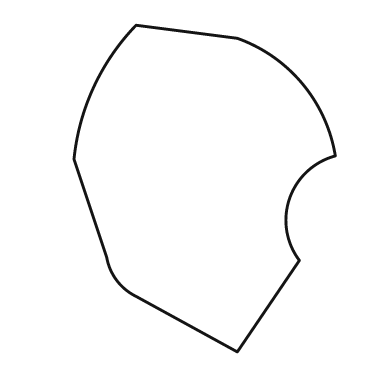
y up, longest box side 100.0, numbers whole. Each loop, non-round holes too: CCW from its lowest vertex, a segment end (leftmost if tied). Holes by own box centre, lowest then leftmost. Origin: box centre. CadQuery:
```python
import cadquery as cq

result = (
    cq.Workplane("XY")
    .moveTo(10.0, -50.0)
    .lineTo(29.0, -22.0)
    .threePointArc((26.0, -3.0), (40.0, 10.0))
    .threePointArc((30.0, 32.0), (10.0, 46.0))
    .lineTo(-21.0, 50.0)
    .threePointArc((-34.0, 31.0), (-40.0, 9.0))
    .lineTo(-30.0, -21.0)
    .threePointArc((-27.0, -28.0), (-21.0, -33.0))
    .close()
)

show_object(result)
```